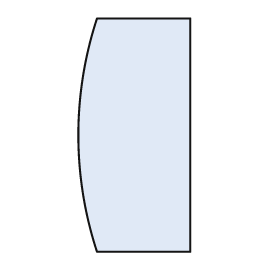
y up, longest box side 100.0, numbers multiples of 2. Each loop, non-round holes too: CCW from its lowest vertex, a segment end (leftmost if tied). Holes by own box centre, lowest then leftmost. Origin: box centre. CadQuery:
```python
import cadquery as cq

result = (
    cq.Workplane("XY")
    .moveTo(-16.0, -50.0)
    .lineTo(24.0, -50.0)
    .lineTo(24.0, 50.0)
    .lineTo(-16.0, 50.0)
    .threePointArc((-24.0, 0.0), (-16.0, -50.0))
    .close()
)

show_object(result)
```